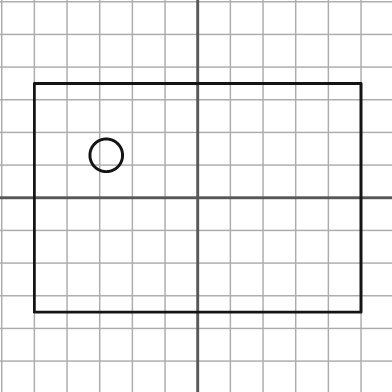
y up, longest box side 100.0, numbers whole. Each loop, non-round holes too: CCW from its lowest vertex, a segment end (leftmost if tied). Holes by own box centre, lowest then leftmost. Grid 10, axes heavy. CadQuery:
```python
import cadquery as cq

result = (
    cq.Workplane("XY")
    .moveTo(-50.0, -35.0)
    .lineTo(50.0, -35.0)
    .lineTo(50.0, 35.0)
    .lineTo(-50.0, 35.0)
    .close()
    .moveTo(-28.0, 13.0)
    .circle(5.0)
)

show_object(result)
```